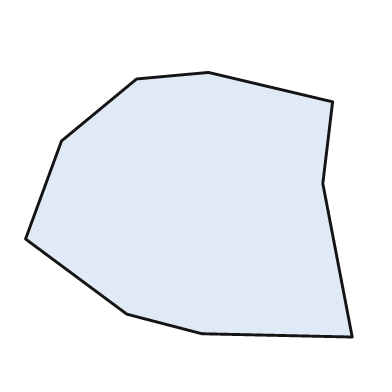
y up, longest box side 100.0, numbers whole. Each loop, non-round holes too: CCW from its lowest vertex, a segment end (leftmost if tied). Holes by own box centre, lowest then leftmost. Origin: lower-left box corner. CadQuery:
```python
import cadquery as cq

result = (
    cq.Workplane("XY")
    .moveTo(100.0, 0.0)
    .lineTo(91.0, 47.0)
    .lineTo(94.0, 72.0)
    .lineTo(56.0, 81.0)
    .lineTo(34.0, 79.0)
    .lineTo(11.0, 60.0)
    .lineTo(0.0, 30.0)
    .lineTo(31.0, 7.0)
    .lineTo(54.0, 1.0)
    .close()
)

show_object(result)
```